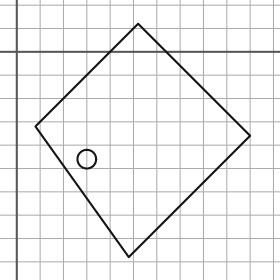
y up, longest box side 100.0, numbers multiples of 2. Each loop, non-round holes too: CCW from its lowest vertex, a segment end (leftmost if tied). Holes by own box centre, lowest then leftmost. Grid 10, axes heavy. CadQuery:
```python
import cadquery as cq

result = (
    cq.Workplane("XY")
    .moveTo(48.0, -88.0)
    .lineTo(100.0, -36.0)
    .lineTo(52.0, 12.0)
    .lineTo(8.0, -32.0)
    .close()
    .moveTo(30.0, -46.0)
    .circle(4.0)
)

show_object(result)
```